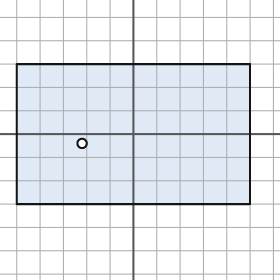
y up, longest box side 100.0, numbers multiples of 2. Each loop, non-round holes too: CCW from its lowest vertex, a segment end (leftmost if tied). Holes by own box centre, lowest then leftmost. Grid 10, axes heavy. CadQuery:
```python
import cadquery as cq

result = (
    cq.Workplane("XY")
    .moveTo(-50.0, -30.0)
    .lineTo(50.0, -30.0)
    .lineTo(50.0, 30.0)
    .lineTo(-50.0, 30.0)
    .close()
    .moveTo(-22.0, -4.0)
    .circle(2.0)
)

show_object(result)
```